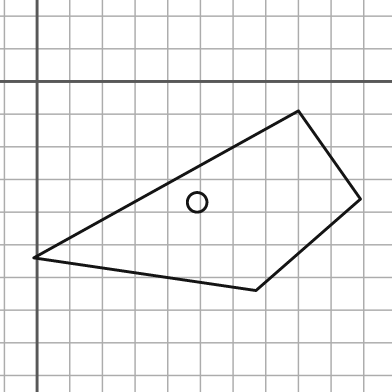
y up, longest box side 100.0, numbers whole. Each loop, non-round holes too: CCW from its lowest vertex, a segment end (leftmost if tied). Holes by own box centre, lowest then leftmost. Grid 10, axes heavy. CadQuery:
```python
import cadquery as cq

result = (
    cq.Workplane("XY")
    .moveTo(67.0, -64.0)
    .lineTo(99.0, -36.0)
    .lineTo(80.0, -9.0)
    .lineTo(-1.0, -54.0)
    .close()
    .moveTo(49.0, -37.0)
    .circle(3.0)
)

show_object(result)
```